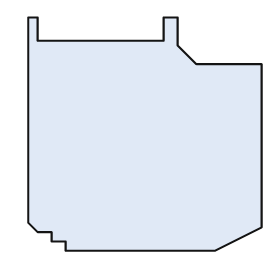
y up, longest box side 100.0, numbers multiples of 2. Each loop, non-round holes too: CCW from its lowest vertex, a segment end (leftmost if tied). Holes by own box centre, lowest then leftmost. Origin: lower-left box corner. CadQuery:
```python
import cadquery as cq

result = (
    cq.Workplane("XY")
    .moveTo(16.0, 0.0)
    .lineTo(80.0, 0.0)
    .lineTo(100.0, 10.0)
    .lineTo(100.0, 80.0)
    .lineTo(72.0, 80.0)
    .lineTo(64.0, 88.0)
    .lineTo(64.0, 100.0)
    .lineTo(58.0, 100.0)
    .lineTo(58.0, 90.0)
    .lineTo(4.0, 90.0)
    .lineTo(4.0, 100.0)
    .lineTo(0.0, 100.0)
    .lineTo(0.0, 12.0)
    .lineTo(4.0, 8.0)
    .lineTo(10.0, 8.0)
    .lineTo(10.0, 4.0)
    .lineTo(16.0, 4.0)
    .close()
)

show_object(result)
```